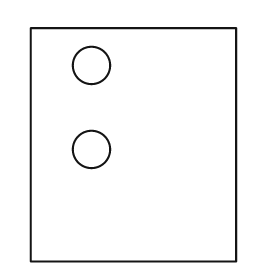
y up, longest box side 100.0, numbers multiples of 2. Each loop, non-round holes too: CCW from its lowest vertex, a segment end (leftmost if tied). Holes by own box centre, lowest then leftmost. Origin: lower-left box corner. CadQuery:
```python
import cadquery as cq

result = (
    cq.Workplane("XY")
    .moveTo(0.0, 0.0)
    .lineTo(88.0, 0.0)
    .lineTo(88.0, 100.0)
    .lineTo(0.0, 100.0)
    .close()
    .moveTo(26.0, 48.0)
    .circle(8.0)
    .moveTo(26.0, 84.0)
    .circle(8.0)
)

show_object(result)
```